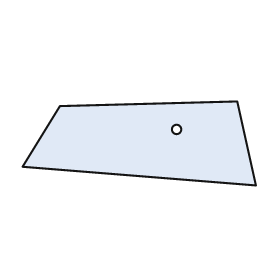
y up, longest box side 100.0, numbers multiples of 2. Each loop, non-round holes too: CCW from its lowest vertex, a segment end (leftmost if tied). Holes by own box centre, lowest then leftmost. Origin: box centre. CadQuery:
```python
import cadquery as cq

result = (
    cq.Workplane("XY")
    .moveTo(50.0, -18.0)
    .lineTo(42.0, 18.0)
    .lineTo(-34.0, 16.0)
    .lineTo(-50.0, -10.0)
    .close()
    .moveTo(16.0, 6.0)
    .circle(2.0)
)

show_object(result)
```